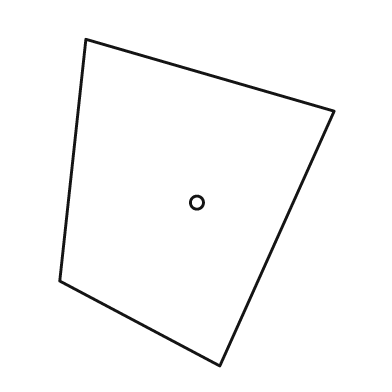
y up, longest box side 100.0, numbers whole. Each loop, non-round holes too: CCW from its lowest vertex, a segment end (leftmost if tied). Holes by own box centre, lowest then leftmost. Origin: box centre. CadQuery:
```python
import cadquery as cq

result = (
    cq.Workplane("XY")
    .moveTo(7.0, -50.0)
    .lineTo(42.0, 28.0)
    .lineTo(-34.0, 50.0)
    .lineTo(-42.0, -24.0)
    .close()
    .moveTo(0.0, 0.0)
    .circle(2.0)
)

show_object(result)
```